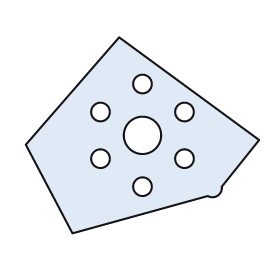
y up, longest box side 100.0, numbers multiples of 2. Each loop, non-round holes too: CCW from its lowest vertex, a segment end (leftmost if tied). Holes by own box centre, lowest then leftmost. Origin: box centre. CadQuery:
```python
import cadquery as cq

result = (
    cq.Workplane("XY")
    .moveTo(-30.0, -42.0)
    .lineTo(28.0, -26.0)
    .threePointArc((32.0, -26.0), (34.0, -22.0))
    .lineTo(50.0, -2.0)
    .lineTo(-10.0, 42.0)
    .lineTo(-50.0, -4.0)
    .close()
    .moveTo(0.0, -22.0)
    .circle(4.0)
    .moveTo(-18.0, -10.0)
    .circle(4.0)
    .moveTo(18.0, -10.0)
    .circle(4.0)
    .moveTo(0.0, 0.0)
    .circle(8.0)
    .moveTo(-18.0, 10.0)
    .circle(4.0)
    .moveTo(18.0, 10.0)
    .circle(4.0)
    .moveTo(0.0, 22.0)
    .circle(4.0)
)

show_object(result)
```